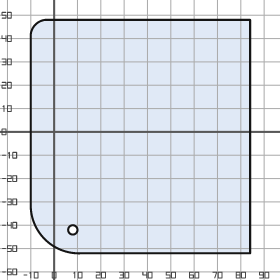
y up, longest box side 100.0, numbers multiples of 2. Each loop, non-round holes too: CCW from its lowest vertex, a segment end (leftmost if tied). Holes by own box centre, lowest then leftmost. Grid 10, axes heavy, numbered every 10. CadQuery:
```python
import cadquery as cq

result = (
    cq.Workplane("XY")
    .moveTo(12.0, -52.0)
    .lineTo(84.0, -52.0)
    .lineTo(84.0, 48.0)
    .lineTo(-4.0, 48.0)
    .threePointArc((-8.0, 46.0), (-10.0, 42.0))
    .lineTo(-10.0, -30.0)
    .threePointArc((-4.0, -46.0), (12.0, -52.0))
    .close()
    .moveTo(8.0, -42.0)
    .circle(2.0)
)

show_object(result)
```